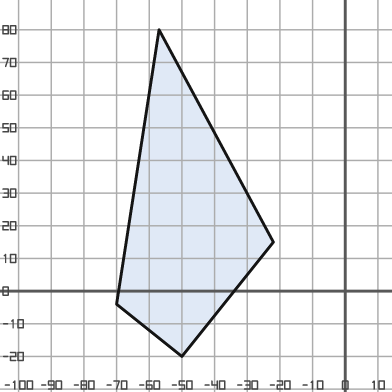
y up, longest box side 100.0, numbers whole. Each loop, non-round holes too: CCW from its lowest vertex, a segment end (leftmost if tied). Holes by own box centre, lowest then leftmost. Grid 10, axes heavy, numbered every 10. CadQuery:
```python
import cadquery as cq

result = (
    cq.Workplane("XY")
    .moveTo(-50.0, -20.0)
    .lineTo(-22.0, 15.0)
    .lineTo(-57.0, 80.0)
    .lineTo(-70.0, -4.0)
    .close()
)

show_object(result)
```